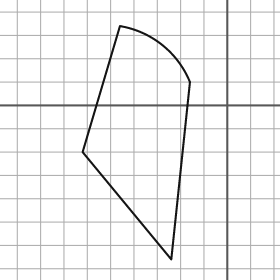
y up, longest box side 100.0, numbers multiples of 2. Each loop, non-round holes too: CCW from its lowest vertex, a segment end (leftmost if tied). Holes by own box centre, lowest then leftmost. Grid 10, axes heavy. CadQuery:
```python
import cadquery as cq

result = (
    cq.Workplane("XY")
    .moveTo(-24.0, -66.0)
    .lineTo(-16.0, 10.0)
    .threePointArc((-28.0, 26.0), (-46.0, 34.0))
    .lineTo(-62.0, -20.0)
    .close()
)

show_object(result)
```